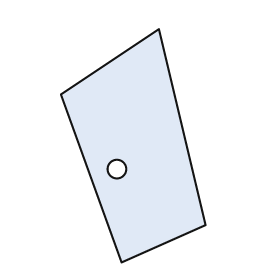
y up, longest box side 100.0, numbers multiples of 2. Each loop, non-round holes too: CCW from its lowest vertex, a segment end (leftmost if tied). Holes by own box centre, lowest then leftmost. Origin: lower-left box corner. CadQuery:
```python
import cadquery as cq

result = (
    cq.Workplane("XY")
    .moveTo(26.0, 0.0)
    .lineTo(62.0, 16.0)
    .lineTo(42.0, 100.0)
    .lineTo(0.0, 72.0)
    .close()
    .moveTo(24.0, 40.0)
    .circle(4.0)
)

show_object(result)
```